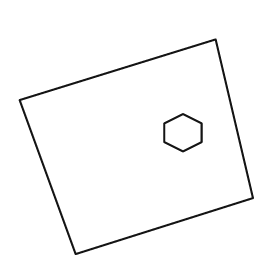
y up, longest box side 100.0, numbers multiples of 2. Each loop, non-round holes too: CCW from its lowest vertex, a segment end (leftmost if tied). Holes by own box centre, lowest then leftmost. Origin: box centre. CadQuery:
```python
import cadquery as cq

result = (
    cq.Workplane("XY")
    .moveTo(-26.0, -46.0)
    .lineTo(50.0, -22.0)
    .lineTo(34.0, 46.0)
    .lineTo(-50.0, 20.0)
    .close()
    .moveTo(20.0, -2.0)
    .lineTo(28.0, 2.0)
    .lineTo(28.0, 10.0)
    .lineTo(20.0, 14.0)
    .lineTo(12.0, 10.0)
    .lineTo(12.0, 2.0)
    .close()
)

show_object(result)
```